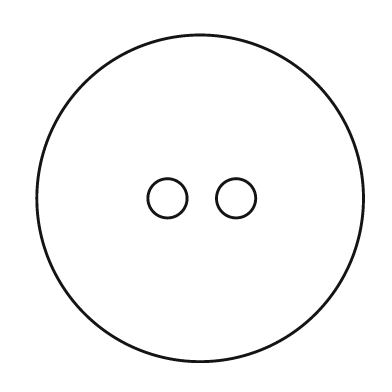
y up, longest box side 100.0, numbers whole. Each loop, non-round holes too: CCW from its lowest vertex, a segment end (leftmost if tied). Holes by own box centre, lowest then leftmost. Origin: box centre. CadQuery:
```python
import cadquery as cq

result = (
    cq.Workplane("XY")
    .moveTo(0.0, 0.0)
    .circle(50.0)
    .moveTo(-10.0, 0.0)
    .circle(6.0)
    .moveTo(11.0, 0.0)
    .circle(6.0)
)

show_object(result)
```